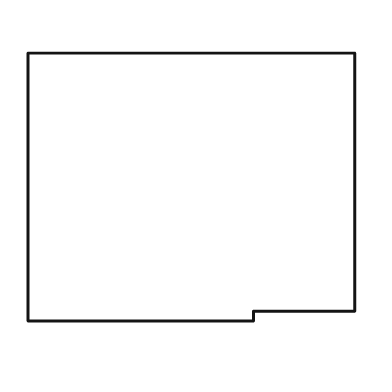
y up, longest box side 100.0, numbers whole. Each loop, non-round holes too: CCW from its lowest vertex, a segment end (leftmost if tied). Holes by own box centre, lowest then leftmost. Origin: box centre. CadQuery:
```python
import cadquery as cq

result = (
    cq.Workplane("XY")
    .moveTo(-50.0, -41.0)
    .lineTo(19.0, -41.0)
    .lineTo(19.0, -38.0)
    .lineTo(50.0, -38.0)
    .lineTo(50.0, 41.0)
    .lineTo(-50.0, 41.0)
    .close()
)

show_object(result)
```